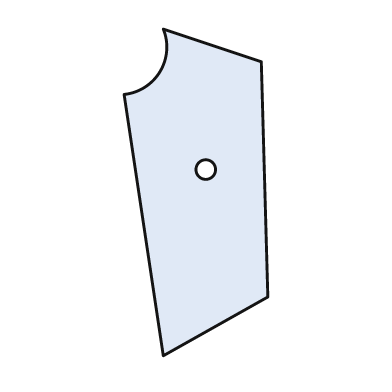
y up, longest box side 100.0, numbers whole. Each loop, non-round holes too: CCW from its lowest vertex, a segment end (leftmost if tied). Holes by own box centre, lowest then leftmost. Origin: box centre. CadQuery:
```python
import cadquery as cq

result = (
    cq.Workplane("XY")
    .moveTo(-10.0, -50.0)
    .lineTo(22.0, -32.0)
    .lineTo(20.0, 40.0)
    .lineTo(-10.0, 50.0)
    .threePointArc((-11.0, 37.0), (-22.0, 30.0))
    .close()
    .moveTo(3.0, 7.0)
    .circle(3.0)
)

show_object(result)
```